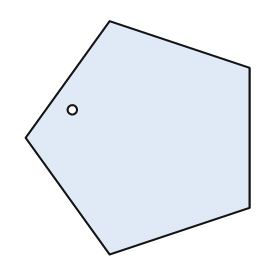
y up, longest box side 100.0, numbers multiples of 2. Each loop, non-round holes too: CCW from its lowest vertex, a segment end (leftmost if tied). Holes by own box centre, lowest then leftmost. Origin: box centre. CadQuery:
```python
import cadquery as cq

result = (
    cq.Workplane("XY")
    .moveTo(-12.0, -50.0)
    .lineTo(48.0, -30.0)
    .lineTo(48.0, 30.0)
    .lineTo(-12.0, 50.0)
    .lineTo(-48.0, 0.0)
    .close()
    .moveTo(-28.0, 12.0)
    .circle(2.0)
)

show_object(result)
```